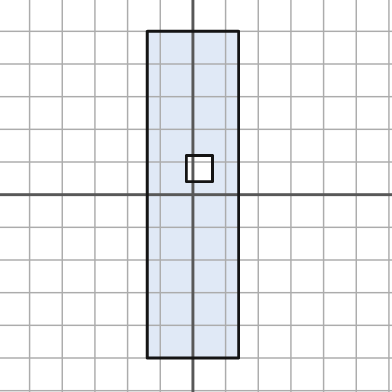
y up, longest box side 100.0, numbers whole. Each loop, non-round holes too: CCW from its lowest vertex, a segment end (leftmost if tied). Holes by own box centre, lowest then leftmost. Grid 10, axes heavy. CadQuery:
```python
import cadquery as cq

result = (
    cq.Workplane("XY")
    .moveTo(-14.0, -50.0)
    .lineTo(14.0, -50.0)
    .lineTo(14.0, 50.0)
    .lineTo(-14.0, 50.0)
    .close()
    .moveTo(-2.0, 4.0)
    .lineTo(6.0, 4.0)
    .lineTo(6.0, 12.0)
    .lineTo(-2.0, 12.0)
    .close()
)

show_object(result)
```